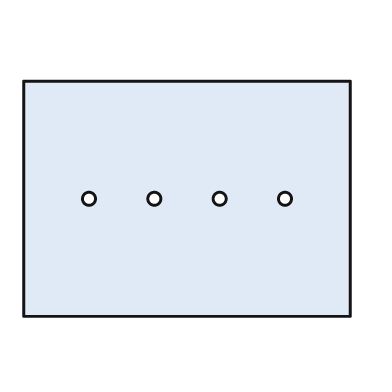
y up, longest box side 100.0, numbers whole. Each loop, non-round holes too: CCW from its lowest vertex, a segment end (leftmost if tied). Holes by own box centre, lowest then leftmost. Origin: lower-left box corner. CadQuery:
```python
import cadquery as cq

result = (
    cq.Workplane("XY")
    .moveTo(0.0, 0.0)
    .lineTo(100.0, 0.0)
    .lineTo(100.0, 72.0)
    .lineTo(0.0, 72.0)
    .close()
    .moveTo(20.0, 36.0)
    .circle(2.0)
    .moveTo(40.0, 36.0)
    .circle(2.0)
    .moveTo(60.0, 36.0)
    .circle(2.0)
    .moveTo(80.0, 36.0)
    .circle(2.0)
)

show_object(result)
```